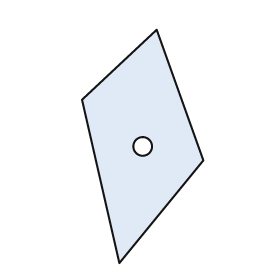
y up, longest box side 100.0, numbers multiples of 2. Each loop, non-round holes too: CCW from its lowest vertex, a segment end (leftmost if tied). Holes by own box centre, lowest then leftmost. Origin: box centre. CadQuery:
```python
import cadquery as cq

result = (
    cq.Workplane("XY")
    .moveTo(-10.0, -50.0)
    .lineTo(26.0, -6.0)
    .lineTo(6.0, 50.0)
    .lineTo(-26.0, 20.0)
    .close()
    .moveTo(0.0, 0.0)
    .circle(4.0)
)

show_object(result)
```